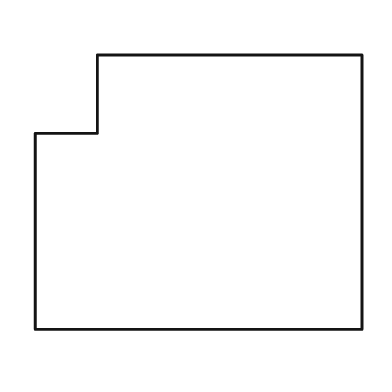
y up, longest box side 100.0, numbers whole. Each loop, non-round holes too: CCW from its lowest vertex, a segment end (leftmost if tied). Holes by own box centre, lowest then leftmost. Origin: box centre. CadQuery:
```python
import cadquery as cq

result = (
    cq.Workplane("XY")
    .moveTo(-50.0, -42.0)
    .lineTo(50.0, -42.0)
    .lineTo(50.0, 42.0)
    .lineTo(-31.0, 42.0)
    .lineTo(-31.0, 18.0)
    .lineTo(-50.0, 18.0)
    .close()
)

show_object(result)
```